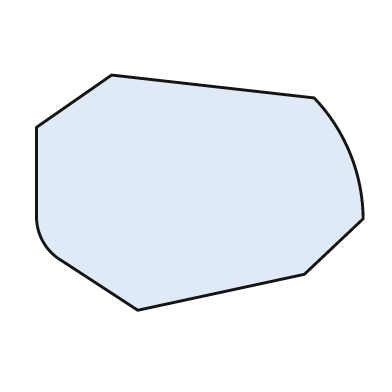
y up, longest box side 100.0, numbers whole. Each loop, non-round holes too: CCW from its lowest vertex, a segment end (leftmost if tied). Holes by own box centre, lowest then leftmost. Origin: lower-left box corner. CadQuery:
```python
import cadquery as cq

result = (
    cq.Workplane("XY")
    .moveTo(31.0, 0.0)
    .lineTo(82.0, 11.0)
    .lineTo(100.0, 28.0)
    .threePointArc((96.0, 48.0), (85.0, 65.0))
    .lineTo(23.0, 72.0)
    .lineTo(0.0, 56.0)
    .lineTo(0.0, 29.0)
    .threePointArc((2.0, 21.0), (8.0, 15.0))
    .close()
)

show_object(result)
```